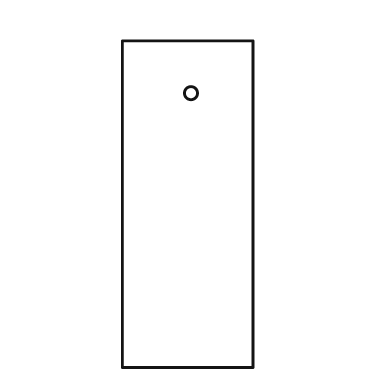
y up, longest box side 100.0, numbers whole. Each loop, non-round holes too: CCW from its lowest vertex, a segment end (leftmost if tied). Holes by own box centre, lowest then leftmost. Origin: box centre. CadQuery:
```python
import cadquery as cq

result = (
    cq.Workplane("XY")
    .moveTo(-20.0, -50.0)
    .lineTo(20.0, -50.0)
    .lineTo(20.0, 50.0)
    .lineTo(-20.0, 50.0)
    .close()
    .moveTo(1.0, 34.0)
    .circle(2.0)
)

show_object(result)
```